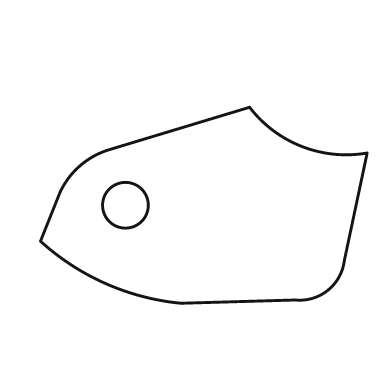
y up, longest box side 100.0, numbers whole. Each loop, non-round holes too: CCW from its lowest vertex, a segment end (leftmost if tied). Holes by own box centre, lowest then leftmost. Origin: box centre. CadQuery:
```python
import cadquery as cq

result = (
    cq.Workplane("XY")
    .moveTo(-7.0, -30.0)
    .lineTo(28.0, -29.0)
    .threePointArc((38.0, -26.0), (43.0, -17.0))
    .lineTo(50.0, 16.0)
    .threePointArc((30.0, 18.0), (14.0, 30.0))
    .lineTo(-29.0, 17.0)
    .threePointArc((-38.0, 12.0), (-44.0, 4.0))
    .lineTo(-50.0, -11.0)
    .threePointArc((-30.0, -24.0), (-7.0, -30.0))
    .close()
    .moveTo(-24.0, 0.0)
    .circle(7.0)
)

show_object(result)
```